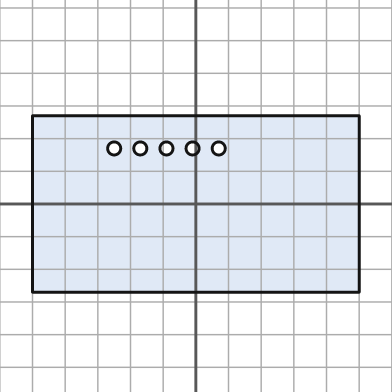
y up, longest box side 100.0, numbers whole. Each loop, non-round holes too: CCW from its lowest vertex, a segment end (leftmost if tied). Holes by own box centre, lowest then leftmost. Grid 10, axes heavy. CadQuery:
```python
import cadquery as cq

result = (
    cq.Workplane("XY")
    .moveTo(-50.0, -27.0)
    .lineTo(50.0, -27.0)
    .lineTo(50.0, 27.0)
    .lineTo(-50.0, 27.0)
    .close()
    .moveTo(-25.0, 17.0)
    .circle(2.0)
    .moveTo(-17.0, 17.0)
    .circle(2.0)
    .moveTo(-9.0, 17.0)
    .circle(2.0)
    .moveTo(-1.0, 17.0)
    .circle(2.0)
    .moveTo(7.0, 17.0)
    .circle(2.0)
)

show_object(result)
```